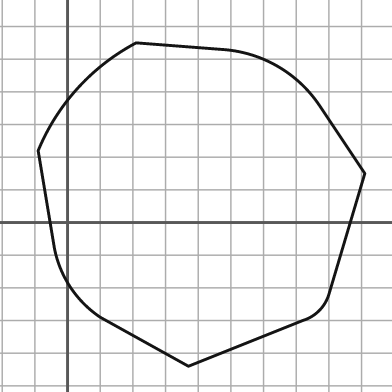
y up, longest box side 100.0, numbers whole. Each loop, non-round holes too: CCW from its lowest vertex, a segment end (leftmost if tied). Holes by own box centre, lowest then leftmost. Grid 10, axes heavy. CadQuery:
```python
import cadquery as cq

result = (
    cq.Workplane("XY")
    .moveTo(37.0, -44.0)
    .lineTo(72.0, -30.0)
    .threePointArc((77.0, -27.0), (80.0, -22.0))
    .lineTo(91.0, 15.0)
    .lineTo(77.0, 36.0)
    .threePointArc((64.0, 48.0), (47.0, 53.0))
    .lineTo(21.0, 55.0)
    .threePointArc((3.0, 41.0), (-9.0, 22.0))
    .lineTo(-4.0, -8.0)
    .threePointArc((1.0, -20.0), (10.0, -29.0))
    .close()
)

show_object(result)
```